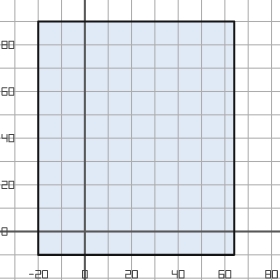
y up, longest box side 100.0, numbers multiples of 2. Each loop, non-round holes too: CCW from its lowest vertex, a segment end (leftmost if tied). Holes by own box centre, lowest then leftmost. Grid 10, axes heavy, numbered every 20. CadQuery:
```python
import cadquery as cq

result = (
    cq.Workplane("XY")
    .moveTo(-20.0, -10.0)
    .lineTo(64.0, -10.0)
    .lineTo(64.0, 90.0)
    .lineTo(-20.0, 90.0)
    .close()
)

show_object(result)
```